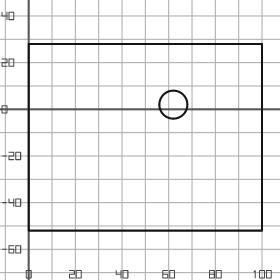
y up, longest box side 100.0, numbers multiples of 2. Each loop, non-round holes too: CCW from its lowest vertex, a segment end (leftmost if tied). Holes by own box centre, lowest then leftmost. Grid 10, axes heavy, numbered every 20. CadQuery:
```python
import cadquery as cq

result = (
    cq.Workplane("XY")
    .moveTo(0.0, -52.0)
    .lineTo(100.0, -52.0)
    .lineTo(100.0, 28.0)
    .lineTo(0.0, 28.0)
    .close()
    .moveTo(62.0, 2.0)
    .circle(6.0)
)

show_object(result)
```